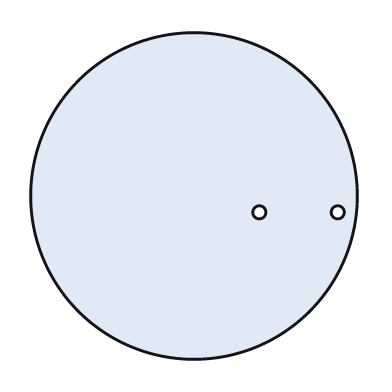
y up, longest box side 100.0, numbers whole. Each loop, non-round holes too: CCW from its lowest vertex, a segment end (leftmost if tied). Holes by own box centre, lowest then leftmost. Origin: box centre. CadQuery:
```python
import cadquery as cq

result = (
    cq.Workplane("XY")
    .moveTo(0.0, 0.0)
    .circle(50.0)
    .moveTo(20.0, -5.0)
    .circle(2.0)
    .moveTo(44.0, -5.0)
    .circle(2.0)
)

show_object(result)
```